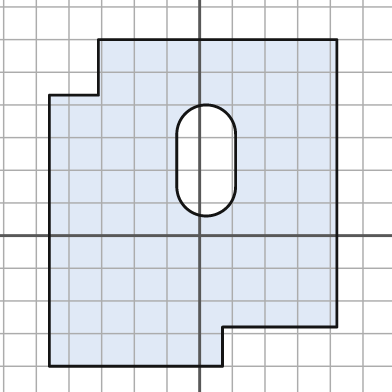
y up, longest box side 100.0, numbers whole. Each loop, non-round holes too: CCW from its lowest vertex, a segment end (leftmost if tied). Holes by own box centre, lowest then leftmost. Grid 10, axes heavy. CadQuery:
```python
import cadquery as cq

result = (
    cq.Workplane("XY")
    .moveTo(-46.0, -40.0)
    .lineTo(7.0, -40.0)
    .lineTo(7.0, -28.0)
    .lineTo(42.0, -28.0)
    .lineTo(42.0, 60.0)
    .lineTo(-31.0, 60.0)
    .lineTo(-31.0, 43.0)
    .lineTo(-46.0, 43.0)
    .close()
    .moveTo(-7.0, 15.0)
    .threePointArc((2.0, 6.0), (11.0, 15.0))
    .lineTo(11.0, 31.0)
    .threePointArc((2.0, 40.0), (-7.0, 31.0))
    .close()
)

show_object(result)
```